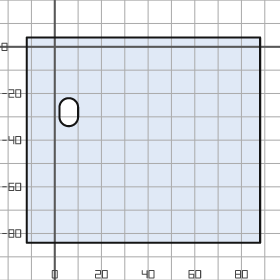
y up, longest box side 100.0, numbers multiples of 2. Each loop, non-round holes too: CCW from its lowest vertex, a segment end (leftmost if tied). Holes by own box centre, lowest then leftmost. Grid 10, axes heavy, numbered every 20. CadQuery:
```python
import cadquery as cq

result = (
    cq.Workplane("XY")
    .moveTo(-12.0, -84.0)
    .lineTo(88.0, -84.0)
    .lineTo(88.0, 4.0)
    .lineTo(-12.0, 4.0)
    .close()
    .moveTo(2.0, -30.0)
    .threePointArc((6.0, -34.0), (10.0, -30.0))
    .lineTo(10.0, -26.0)
    .threePointArc((6.0, -22.0), (2.0, -26.0))
    .close()
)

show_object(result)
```